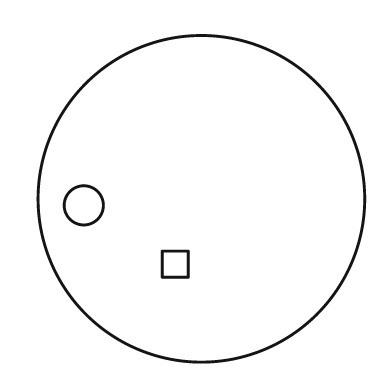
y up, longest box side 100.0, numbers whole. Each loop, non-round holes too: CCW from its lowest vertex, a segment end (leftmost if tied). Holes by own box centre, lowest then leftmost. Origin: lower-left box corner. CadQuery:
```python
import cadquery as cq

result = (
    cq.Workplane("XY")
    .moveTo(50.0, 50.0)
    .circle(50.0)
    .moveTo(38.0, 26.0)
    .lineTo(46.0, 26.0)
    .lineTo(46.0, 34.0)
    .lineTo(38.0, 34.0)
    .close()
    .moveTo(14.0, 48.0)
    .circle(6.0)
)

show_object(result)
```